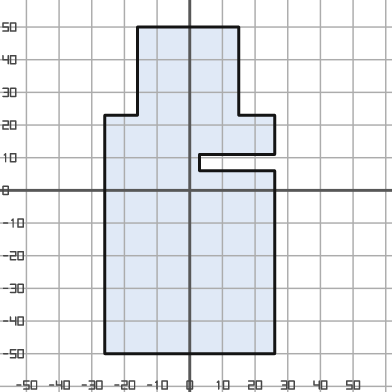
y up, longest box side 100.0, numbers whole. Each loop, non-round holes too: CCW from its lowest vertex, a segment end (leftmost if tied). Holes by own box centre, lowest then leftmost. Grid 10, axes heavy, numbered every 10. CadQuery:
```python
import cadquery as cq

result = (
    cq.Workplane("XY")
    .moveTo(-26.0, -50.0)
    .lineTo(26.0, -50.0)
    .lineTo(26.0, 6.0)
    .lineTo(3.0, 6.0)
    .lineTo(3.0, 11.0)
    .lineTo(26.0, 11.0)
    .lineTo(26.0, 23.0)
    .lineTo(15.0, 23.0)
    .lineTo(15.0, 50.0)
    .lineTo(-16.0, 50.0)
    .lineTo(-16.0, 23.0)
    .lineTo(-26.0, 23.0)
    .close()
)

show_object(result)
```